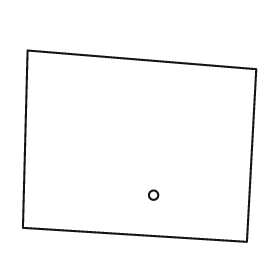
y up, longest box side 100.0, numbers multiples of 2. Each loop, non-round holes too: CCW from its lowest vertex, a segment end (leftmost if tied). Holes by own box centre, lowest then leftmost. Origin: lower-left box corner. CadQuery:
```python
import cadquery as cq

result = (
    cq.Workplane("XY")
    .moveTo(96.0, 0.0)
    .lineTo(100.0, 74.0)
    .lineTo(2.0, 82.0)
    .lineTo(0.0, 6.0)
    .close()
    .moveTo(56.0, 20.0)
    .circle(2.0)
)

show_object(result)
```